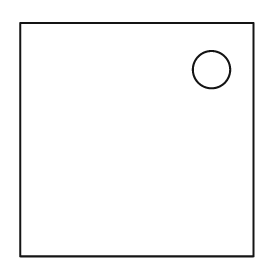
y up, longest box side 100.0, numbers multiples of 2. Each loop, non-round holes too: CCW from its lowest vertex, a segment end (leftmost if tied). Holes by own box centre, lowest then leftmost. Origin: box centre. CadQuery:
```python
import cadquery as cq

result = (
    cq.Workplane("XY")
    .moveTo(-50.0, -50.0)
    .lineTo(50.0, -50.0)
    .lineTo(50.0, 50.0)
    .lineTo(-50.0, 50.0)
    .close()
    .moveTo(32.0, 30.0)
    .circle(8.0)
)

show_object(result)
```